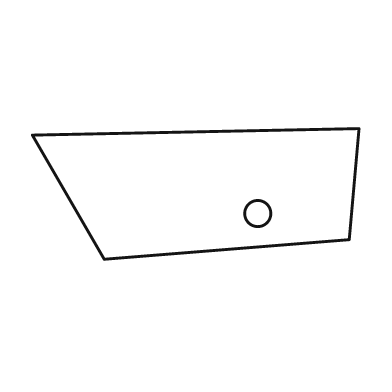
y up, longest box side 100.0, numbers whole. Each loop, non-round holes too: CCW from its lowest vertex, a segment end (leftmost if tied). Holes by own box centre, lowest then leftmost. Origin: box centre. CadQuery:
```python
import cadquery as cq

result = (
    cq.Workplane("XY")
    .moveTo(-28.0, -20.0)
    .lineTo(47.0, -14.0)
    .lineTo(50.0, 20.0)
    .lineTo(-50.0, 18.0)
    .close()
    .moveTo(19.0, -6.0)
    .circle(4.0)
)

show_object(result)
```